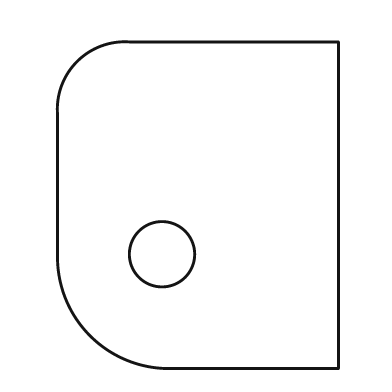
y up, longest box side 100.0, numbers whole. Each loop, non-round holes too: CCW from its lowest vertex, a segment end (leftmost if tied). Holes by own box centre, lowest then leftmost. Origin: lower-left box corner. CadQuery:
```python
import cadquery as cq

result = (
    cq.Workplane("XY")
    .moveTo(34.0, 0.0)
    .lineTo(86.0, 0.0)
    .lineTo(86.0, 100.0)
    .lineTo(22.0, 100.0)
    .threePointArc((6.0, 94.0), (0.0, 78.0))
    .lineTo(0.0, 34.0)
    .threePointArc((10.0, 10.0), (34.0, 0.0))
    .close()
    .moveTo(32.0, 35.0)
    .circle(10.0)
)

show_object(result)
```